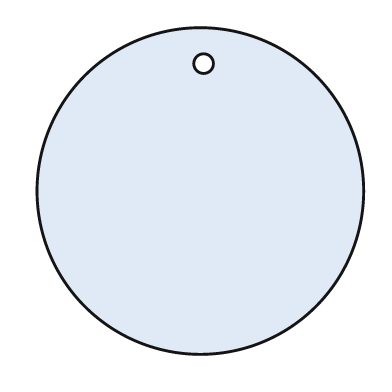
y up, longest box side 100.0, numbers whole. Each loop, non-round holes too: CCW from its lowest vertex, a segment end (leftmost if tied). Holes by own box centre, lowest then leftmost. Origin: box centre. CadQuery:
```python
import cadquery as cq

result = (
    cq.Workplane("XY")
    .moveTo(0.0, 0.0)
    .circle(50.0)
    .moveTo(1.0, 39.0)
    .circle(3.0)
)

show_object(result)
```